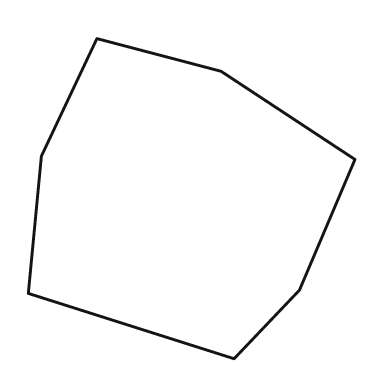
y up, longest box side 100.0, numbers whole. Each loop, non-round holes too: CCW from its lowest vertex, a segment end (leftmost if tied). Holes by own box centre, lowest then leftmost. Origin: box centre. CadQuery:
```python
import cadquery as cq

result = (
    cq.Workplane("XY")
    .moveTo(13.0, -49.0)
    .lineTo(33.0, -28.0)
    .lineTo(50.0, 12.0)
    .lineTo(9.0, 39.0)
    .lineTo(-29.0, 49.0)
    .lineTo(-46.0, 13.0)
    .lineTo(-50.0, -29.0)
    .close()
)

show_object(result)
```